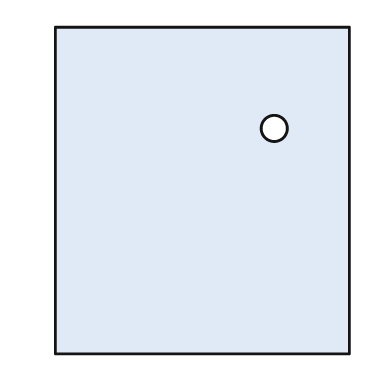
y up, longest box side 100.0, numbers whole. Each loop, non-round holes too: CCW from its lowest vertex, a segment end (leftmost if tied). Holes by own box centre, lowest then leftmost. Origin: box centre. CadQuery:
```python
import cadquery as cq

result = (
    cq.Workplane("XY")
    .moveTo(-45.0, -50.0)
    .lineTo(45.0, -50.0)
    .lineTo(45.0, 50.0)
    .lineTo(-45.0, 50.0)
    .close()
    .moveTo(22.0, 19.0)
    .circle(4.0)
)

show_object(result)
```